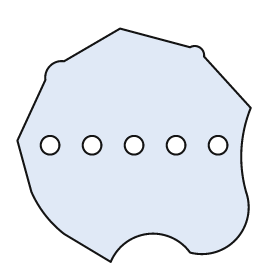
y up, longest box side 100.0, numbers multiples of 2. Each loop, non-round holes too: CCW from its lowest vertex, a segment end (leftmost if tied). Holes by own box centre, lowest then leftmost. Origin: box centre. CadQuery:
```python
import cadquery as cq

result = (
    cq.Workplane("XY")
    .moveTo(-10.0, -50.0)
    .threePointArc((6.0, -38.0), (24.0, -46.0))
    .threePointArc((44.0, -40.0), (48.0, -20.0))
    .threePointArc((46.0, -2.0), (50.0, 16.0))
    .lineTo(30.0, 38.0)
    .threePointArc((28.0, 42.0), (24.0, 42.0))
    .lineTo(-6.0, 50.0)
    .lineTo(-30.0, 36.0)
    .threePointArc((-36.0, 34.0), (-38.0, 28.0))
    .lineTo(-50.0, 2.0)
    .lineTo(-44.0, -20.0)
    .threePointArc((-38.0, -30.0), (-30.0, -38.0))
    .close()
    .moveTo(-36.0, 0.0)
    .circle(4.0)
    .moveTo(-18.0, 0.0)
    .circle(4.0)
    .moveTo(0.0, 0.0)
    .circle(4.0)
    .moveTo(18.0, 0.0)
    .circle(4.0)
    .moveTo(36.0, 0.0)
    .circle(4.0)
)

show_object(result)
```